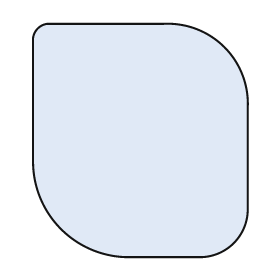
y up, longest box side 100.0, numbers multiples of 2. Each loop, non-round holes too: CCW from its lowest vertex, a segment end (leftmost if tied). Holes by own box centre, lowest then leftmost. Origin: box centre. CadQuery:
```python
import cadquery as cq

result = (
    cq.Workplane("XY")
    .moveTo(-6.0, -50.0)
    .lineTo(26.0, -50.0)
    .threePointArc((40.0, -44.0), (46.0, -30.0))
    .lineTo(46.0, 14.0)
    .threePointArc((36.0, 40.0), (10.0, 50.0))
    .lineTo(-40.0, 50.0)
    .threePointArc((-44.0, 48.0), (-46.0, 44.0))
    .lineTo(-46.0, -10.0)
    .threePointArc((-34.0, -38.0), (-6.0, -50.0))
    .close()
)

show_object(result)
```